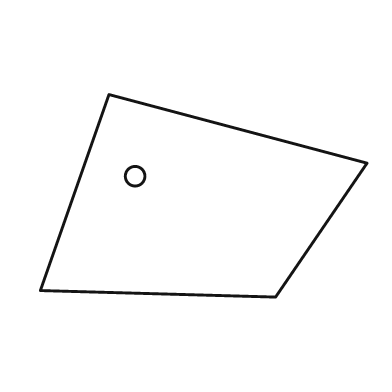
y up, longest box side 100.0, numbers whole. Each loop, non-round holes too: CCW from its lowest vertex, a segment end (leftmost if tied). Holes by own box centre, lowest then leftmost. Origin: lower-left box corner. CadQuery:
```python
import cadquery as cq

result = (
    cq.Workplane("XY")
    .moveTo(72.0, 0.0)
    .lineTo(100.0, 41.0)
    .lineTo(21.0, 62.0)
    .lineTo(0.0, 2.0)
    .close()
    .moveTo(29.0, 37.0)
    .circle(3.0)
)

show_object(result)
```